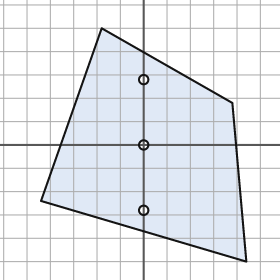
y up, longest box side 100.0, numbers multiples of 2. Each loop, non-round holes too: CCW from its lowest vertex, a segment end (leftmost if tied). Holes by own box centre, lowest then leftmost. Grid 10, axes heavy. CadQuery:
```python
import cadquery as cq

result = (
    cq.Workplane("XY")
    .moveTo(44.0, -50.0)
    .lineTo(38.0, 18.0)
    .lineTo(-18.0, 50.0)
    .lineTo(-44.0, -24.0)
    .close()
    .moveTo(0.0, -28.0)
    .circle(2.0)
    .moveTo(0.0, 0.0)
    .circle(2.0)
    .moveTo(0.0, 28.0)
    .circle(2.0)
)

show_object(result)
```